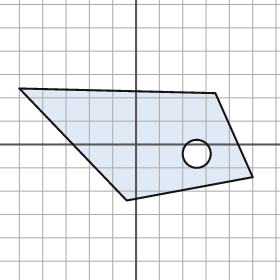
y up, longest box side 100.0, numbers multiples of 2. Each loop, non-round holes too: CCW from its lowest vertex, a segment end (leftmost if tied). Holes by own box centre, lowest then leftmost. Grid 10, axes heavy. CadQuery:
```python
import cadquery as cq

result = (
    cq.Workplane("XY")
    .moveTo(-4.0, -24.0)
    .lineTo(50.0, -14.0)
    .lineTo(34.0, 22.0)
    .lineTo(-50.0, 24.0)
    .close()
    .moveTo(26.0, -4.0)
    .circle(6.0)
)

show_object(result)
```